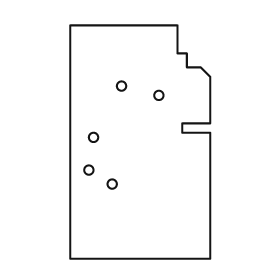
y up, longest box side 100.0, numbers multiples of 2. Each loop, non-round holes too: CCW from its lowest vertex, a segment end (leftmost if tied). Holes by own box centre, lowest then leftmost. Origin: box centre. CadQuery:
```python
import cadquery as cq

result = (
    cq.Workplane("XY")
    .moveTo(-30.0, -50.0)
    .lineTo(30.0, -50.0)
    .lineTo(30.0, 4.0)
    .lineTo(18.0, 4.0)
    .lineTo(18.0, 8.0)
    .lineTo(30.0, 8.0)
    .lineTo(30.0, 28.0)
    .lineTo(26.0, 32.0)
    .lineTo(20.0, 32.0)
    .lineTo(20.0, 38.0)
    .lineTo(16.0, 38.0)
    .lineTo(16.0, 50.0)
    .lineTo(-30.0, 50.0)
    .close()
    .moveTo(-12.0, -18.0)
    .circle(2.0)
    .moveTo(-22.0, -12.0)
    .circle(2.0)
    .moveTo(-20.0, 2.0)
    .circle(2.0)
    .moveTo(8.0, 20.0)
    .circle(2.0)
    .moveTo(-8.0, 24.0)
    .circle(2.0)
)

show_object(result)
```